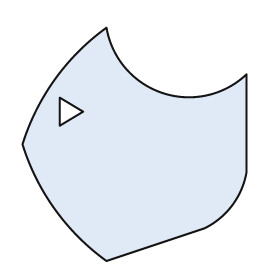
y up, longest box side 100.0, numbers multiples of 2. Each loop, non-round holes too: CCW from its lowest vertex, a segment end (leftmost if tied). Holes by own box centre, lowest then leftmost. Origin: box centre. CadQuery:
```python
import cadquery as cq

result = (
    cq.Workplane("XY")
    .moveTo(-12.0, -50.0)
    .lineTo(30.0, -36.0)
    .threePointArc((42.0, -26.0), (48.0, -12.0))
    .lineTo(48.0, 30.0)
    .threePointArc((12.0, 22.0), (-12.0, 50.0))
    .threePointArc((-34.0, 28.0), (-48.0, 0.0))
    .threePointArc((-34.0, -28.0), (-12.0, -50.0))
    .close()
    .moveTo(-32.0, 8.0)
    .lineTo(-22.0, 14.0)
    .lineTo(-32.0, 20.0)
    .close()
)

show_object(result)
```